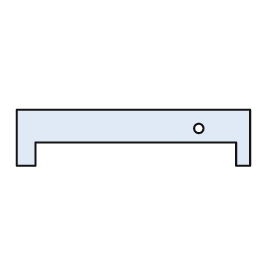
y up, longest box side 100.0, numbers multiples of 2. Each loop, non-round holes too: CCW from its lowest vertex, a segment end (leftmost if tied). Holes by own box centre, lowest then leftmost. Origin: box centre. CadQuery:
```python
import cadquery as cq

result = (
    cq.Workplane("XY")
    .moveTo(-50.0, -12.0)
    .lineTo(-42.0, -12.0)
    .lineTo(-42.0, -2.0)
    .lineTo(44.0, -2.0)
    .lineTo(44.0, -12.0)
    .lineTo(50.0, -12.0)
    .lineTo(50.0, 12.0)
    .lineTo(-50.0, 12.0)
    .close()
    .moveTo(28.0, 4.0)
    .circle(2.0)
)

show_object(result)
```